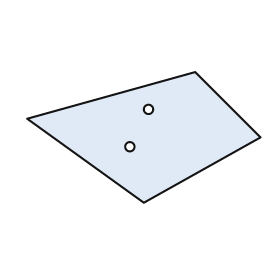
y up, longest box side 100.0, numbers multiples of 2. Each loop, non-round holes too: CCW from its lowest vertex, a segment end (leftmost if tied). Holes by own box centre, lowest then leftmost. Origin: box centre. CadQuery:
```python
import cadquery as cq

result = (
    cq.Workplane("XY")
    .moveTo(0.0, -28.0)
    .lineTo(50.0, 0.0)
    .lineTo(22.0, 28.0)
    .lineTo(-50.0, 8.0)
    .close()
    .moveTo(-6.0, -4.0)
    .circle(2.0)
    .moveTo(2.0, 12.0)
    .circle(2.0)
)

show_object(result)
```